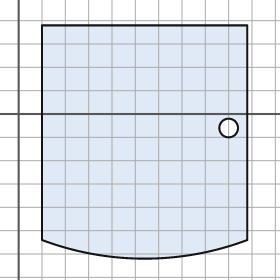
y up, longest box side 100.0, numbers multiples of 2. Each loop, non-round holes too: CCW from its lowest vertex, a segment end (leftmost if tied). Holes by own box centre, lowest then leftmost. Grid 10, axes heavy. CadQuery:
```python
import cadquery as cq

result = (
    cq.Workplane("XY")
    .moveTo(10.0, -54.0)
    .threePointArc((54.0, -62.0), (98.0, -54.0))
    .lineTo(98.0, 38.0)
    .lineTo(10.0, 38.0)
    .close()
    .moveTo(90.0, -6.0)
    .circle(4.0)
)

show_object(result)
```